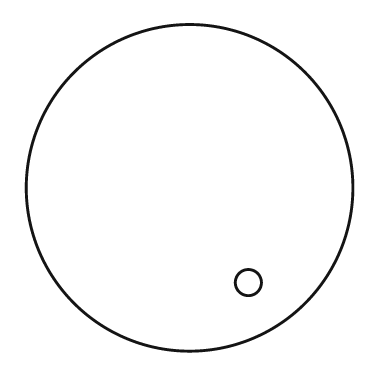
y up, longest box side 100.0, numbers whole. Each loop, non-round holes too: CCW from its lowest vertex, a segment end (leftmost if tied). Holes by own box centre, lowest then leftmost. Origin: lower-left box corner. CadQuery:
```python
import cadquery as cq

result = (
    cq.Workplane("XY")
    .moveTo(50.0, 50.0)
    .circle(50.0)
    .moveTo(68.0, 21.0)
    .circle(4.0)
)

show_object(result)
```